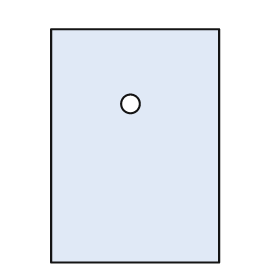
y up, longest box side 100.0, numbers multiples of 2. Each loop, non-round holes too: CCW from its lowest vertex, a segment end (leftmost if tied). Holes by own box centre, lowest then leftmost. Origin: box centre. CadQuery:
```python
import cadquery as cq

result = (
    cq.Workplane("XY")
    .moveTo(-36.0, -50.0)
    .lineTo(36.0, -50.0)
    .lineTo(36.0, 50.0)
    .lineTo(-36.0, 50.0)
    .close()
    .moveTo(-2.0, 18.0)
    .circle(4.0)
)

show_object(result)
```